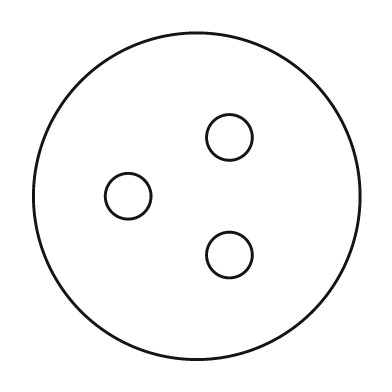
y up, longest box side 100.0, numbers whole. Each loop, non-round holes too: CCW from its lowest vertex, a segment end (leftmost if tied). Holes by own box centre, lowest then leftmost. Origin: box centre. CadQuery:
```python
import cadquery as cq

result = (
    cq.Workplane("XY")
    .moveTo(0.0, 0.0)
    .circle(50.0)
    .moveTo(10.0, -18.0)
    .circle(7.0)
    .moveTo(-21.0, 0.0)
    .circle(7.0)
    .moveTo(10.0, 18.0)
    .circle(7.0)
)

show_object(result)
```